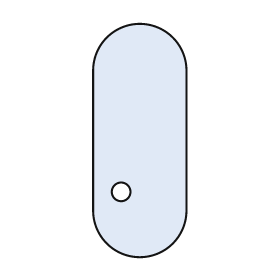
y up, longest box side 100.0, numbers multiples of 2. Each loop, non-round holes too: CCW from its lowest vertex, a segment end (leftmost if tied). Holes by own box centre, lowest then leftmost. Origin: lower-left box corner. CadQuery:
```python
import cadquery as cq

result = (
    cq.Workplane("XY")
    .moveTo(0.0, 20.0)
    .threePointArc((20.0, 0.0), (40.0, 20.0))
    .lineTo(40.0, 80.0)
    .threePointArc((20.0, 100.0), (0.0, 80.0))
    .close()
    .moveTo(12.0, 28.0)
    .circle(4.0)
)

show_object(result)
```